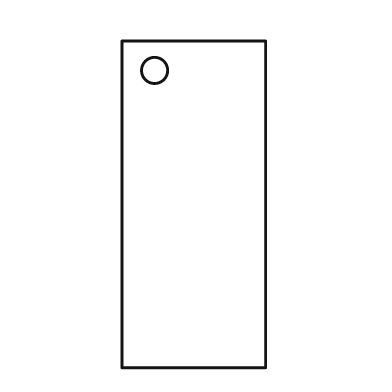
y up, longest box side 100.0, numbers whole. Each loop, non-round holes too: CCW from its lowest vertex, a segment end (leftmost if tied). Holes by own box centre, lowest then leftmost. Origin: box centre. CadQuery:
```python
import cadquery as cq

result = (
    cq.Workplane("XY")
    .moveTo(-22.0, -50.0)
    .lineTo(22.0, -50.0)
    .lineTo(22.0, 50.0)
    .lineTo(-22.0, 50.0)
    .close()
    .moveTo(-12.0, 41.0)
    .circle(4.0)
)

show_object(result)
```